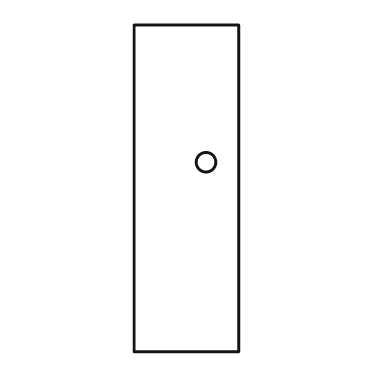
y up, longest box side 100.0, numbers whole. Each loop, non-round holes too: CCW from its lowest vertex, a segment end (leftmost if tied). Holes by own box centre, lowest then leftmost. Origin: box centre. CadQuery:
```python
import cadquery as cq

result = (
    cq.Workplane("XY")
    .moveTo(-16.0, -50.0)
    .lineTo(16.0, -50.0)
    .lineTo(16.0, 50.0)
    .lineTo(-16.0, 50.0)
    .close()
    .moveTo(6.0, 8.0)
    .circle(3.0)
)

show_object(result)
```